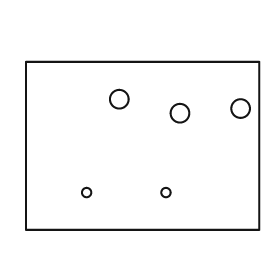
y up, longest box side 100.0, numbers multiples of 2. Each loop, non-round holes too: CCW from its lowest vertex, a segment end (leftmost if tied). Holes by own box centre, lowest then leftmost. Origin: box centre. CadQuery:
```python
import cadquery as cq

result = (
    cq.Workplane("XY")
    .moveTo(-50.0, -36.0)
    .lineTo(50.0, -36.0)
    .lineTo(50.0, 36.0)
    .lineTo(-50.0, 36.0)
    .close()
    .moveTo(-24.0, -20.0)
    .circle(2.0)
    .moveTo(10.0, -20.0)
    .circle(2.0)
    .moveTo(16.0, 14.0)
    .circle(4.0)
    .moveTo(42.0, 16.0)
    .circle(4.0)
    .moveTo(-10.0, 20.0)
    .circle(4.0)
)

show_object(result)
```